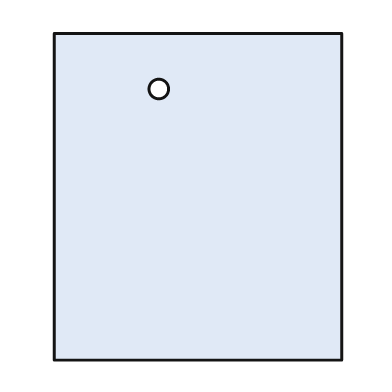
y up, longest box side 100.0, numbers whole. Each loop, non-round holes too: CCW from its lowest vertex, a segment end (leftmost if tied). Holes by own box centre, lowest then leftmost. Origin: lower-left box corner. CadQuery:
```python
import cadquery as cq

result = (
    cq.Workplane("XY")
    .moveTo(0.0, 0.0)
    .lineTo(88.0, 0.0)
    .lineTo(88.0, 100.0)
    .lineTo(0.0, 100.0)
    .close()
    .moveTo(32.0, 83.0)
    .circle(3.0)
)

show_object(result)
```